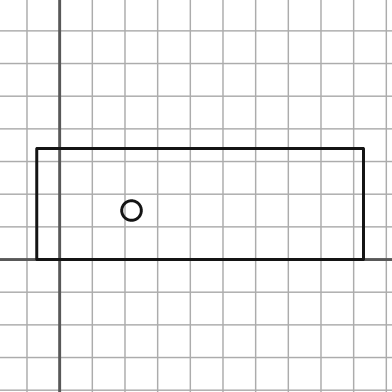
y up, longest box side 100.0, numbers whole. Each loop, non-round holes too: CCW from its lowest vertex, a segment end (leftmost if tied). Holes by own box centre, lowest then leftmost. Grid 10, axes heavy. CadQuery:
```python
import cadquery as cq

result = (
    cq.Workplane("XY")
    .moveTo(-7.0, 0.0)
    .lineTo(93.0, 0.0)
    .lineTo(93.0, 34.0)
    .lineTo(-7.0, 34.0)
    .close()
    .moveTo(22.0, 15.0)
    .circle(3.0)
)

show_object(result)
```